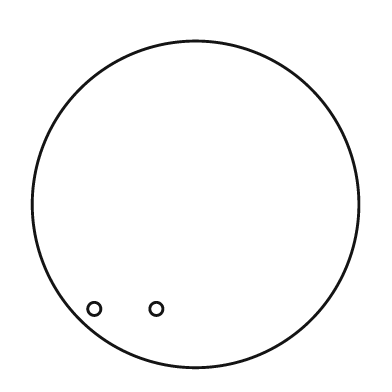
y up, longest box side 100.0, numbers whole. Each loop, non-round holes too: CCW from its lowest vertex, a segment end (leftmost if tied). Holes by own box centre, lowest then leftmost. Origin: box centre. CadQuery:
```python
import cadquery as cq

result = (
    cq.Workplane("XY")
    .moveTo(0.0, 0.0)
    .circle(50.0)
    .moveTo(-31.0, -32.0)
    .circle(2.0)
    .moveTo(-12.0, -32.0)
    .circle(2.0)
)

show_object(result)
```